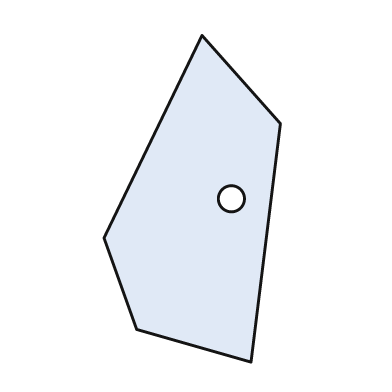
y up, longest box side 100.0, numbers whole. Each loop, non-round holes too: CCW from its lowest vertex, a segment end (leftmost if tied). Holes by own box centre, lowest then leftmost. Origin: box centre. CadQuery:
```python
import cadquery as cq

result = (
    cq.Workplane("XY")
    .moveTo(18.0, -50.0)
    .lineTo(27.0, 23.0)
    .lineTo(3.0, 50.0)
    .lineTo(-27.0, -12.0)
    .lineTo(-17.0, -40.0)
    .close()
    .moveTo(12.0, 0.0)
    .circle(4.0)
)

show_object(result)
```